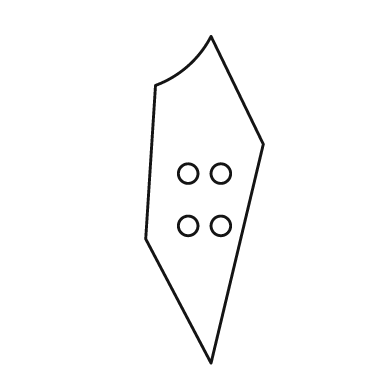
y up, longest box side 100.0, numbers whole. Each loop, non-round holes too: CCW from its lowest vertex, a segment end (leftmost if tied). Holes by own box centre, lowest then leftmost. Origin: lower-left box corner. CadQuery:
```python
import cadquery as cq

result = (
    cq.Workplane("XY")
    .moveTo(20.0, 0.0)
    .lineTo(36.0, 67.0)
    .lineTo(20.0, 100.0)
    .threePointArc((13.0, 91.0), (3.0, 85.0))
    .lineTo(0.0, 38.0)
    .close()
    .moveTo(13.0, 42.0)
    .circle(3.0)
    .moveTo(23.0, 42.0)
    .circle(3.0)
    .moveTo(13.0, 58.0)
    .circle(3.0)
    .moveTo(23.0, 58.0)
    .circle(3.0)
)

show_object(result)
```